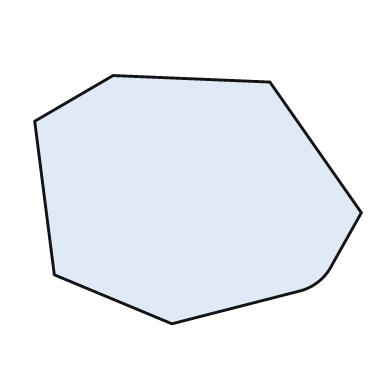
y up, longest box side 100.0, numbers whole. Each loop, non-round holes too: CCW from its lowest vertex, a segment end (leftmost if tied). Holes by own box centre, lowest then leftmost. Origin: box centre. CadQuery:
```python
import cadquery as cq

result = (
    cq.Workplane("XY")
    .moveTo(-8.0, -38.0)
    .lineTo(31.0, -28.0)
    .threePointArc((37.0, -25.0), (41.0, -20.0))
    .lineTo(50.0, -4.0)
    .lineTo(22.0, 36.0)
    .lineTo(-26.0, 38.0)
    .lineTo(-50.0, 24.0)
    .lineTo(-44.0, -23.0)
    .close()
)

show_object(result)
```